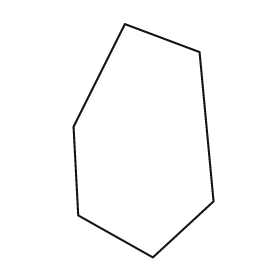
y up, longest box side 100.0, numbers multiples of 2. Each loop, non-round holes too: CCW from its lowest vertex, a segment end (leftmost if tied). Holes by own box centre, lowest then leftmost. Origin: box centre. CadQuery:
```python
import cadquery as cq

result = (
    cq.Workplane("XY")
    .moveTo(4.0, -50.0)
    .lineTo(30.0, -26.0)
    .lineTo(24.0, 38.0)
    .lineTo(-8.0, 50.0)
    .lineTo(-30.0, 6.0)
    .lineTo(-28.0, -32.0)
    .close()
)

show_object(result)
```